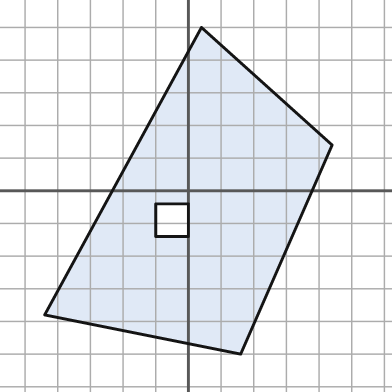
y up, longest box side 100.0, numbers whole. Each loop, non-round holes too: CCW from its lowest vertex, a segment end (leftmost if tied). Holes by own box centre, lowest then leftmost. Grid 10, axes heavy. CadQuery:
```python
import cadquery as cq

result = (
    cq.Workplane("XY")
    .moveTo(16.0, -50.0)
    .lineTo(44.0, 14.0)
    .lineTo(4.0, 50.0)
    .lineTo(-44.0, -38.0)
    .close()
    .moveTo(-10.0, -14.0)
    .lineTo(0.0, -14.0)
    .lineTo(0.0, -4.0)
    .lineTo(-10.0, -4.0)
    .close()
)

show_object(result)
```